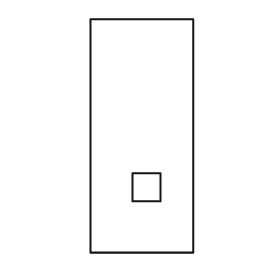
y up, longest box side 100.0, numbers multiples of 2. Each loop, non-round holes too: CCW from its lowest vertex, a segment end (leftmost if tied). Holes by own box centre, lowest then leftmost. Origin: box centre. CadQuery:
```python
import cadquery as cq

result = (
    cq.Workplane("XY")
    .moveTo(-22.0, -50.0)
    .lineTo(22.0, -50.0)
    .lineTo(22.0, 50.0)
    .lineTo(-22.0, 50.0)
    .close()
    .moveTo(-4.0, -28.0)
    .lineTo(8.0, -28.0)
    .lineTo(8.0, -16.0)
    .lineTo(-4.0, -16.0)
    .close()
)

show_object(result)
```